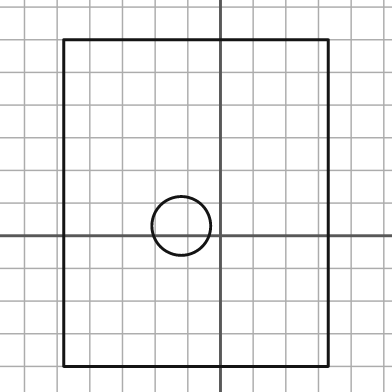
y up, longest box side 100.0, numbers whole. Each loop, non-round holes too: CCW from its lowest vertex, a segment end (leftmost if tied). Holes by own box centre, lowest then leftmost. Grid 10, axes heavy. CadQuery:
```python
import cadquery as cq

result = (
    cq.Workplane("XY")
    .moveTo(-48.0, -40.0)
    .lineTo(33.0, -40.0)
    .lineTo(33.0, 60.0)
    .lineTo(-48.0, 60.0)
    .close()
    .moveTo(-12.0, 3.0)
    .circle(9.0)
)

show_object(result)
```